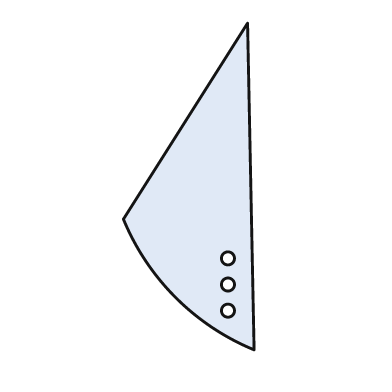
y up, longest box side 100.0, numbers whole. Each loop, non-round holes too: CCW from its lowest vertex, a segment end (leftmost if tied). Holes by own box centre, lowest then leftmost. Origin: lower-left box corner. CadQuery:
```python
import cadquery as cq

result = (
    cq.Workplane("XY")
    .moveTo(40.0, 0.0)
    .lineTo(38.0, 100.0)
    .lineTo(0.0, 40.0)
    .threePointArc((16.0, 16.0), (40.0, 0.0))
    .close()
    .moveTo(32.0, 12.0)
    .circle(2.0)
    .moveTo(32.0, 20.0)
    .circle(2.0)
    .moveTo(32.0, 28.0)
    .circle(2.0)
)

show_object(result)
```